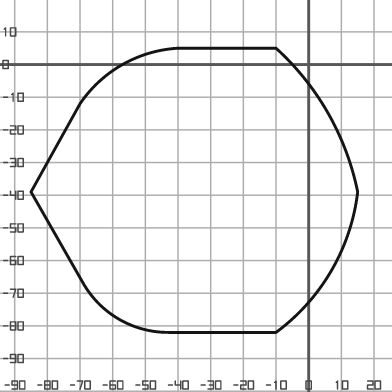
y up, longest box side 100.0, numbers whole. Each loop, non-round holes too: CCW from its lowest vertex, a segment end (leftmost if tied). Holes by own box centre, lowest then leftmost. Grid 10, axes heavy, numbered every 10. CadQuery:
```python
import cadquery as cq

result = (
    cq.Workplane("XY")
    .moveTo(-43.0, -82.0)
    .lineTo(-10.0, -82.0)
    .threePointArc((7.0, -63.0), (15.0, -39.0))
    .threePointArc((6.0, -15.0), (-10.0, 5.0))
    .lineTo(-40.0, 5.0)
    .threePointArc((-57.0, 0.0), (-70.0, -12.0))
    .lineTo(-85.0, -39.0)
    .lineTo(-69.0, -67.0)
    .threePointArc((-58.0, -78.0), (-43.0, -82.0))
    .close()
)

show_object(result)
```